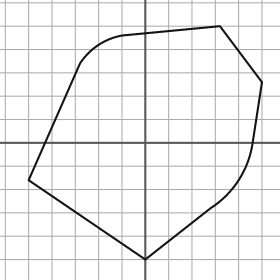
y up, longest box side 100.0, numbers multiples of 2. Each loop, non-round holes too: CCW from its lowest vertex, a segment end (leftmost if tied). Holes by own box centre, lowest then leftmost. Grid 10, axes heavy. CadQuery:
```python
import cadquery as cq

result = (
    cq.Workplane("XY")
    .moveTo(0.0, -50.0)
    .lineTo(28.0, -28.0)
    .threePointArc((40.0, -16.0), (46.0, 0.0))
    .lineTo(50.0, 26.0)
    .lineTo(32.0, 50.0)
    .lineTo(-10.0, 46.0)
    .threePointArc((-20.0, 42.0), (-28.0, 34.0))
    .lineTo(-50.0, -16.0)
    .close()
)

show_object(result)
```